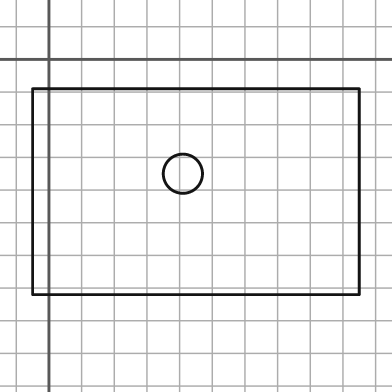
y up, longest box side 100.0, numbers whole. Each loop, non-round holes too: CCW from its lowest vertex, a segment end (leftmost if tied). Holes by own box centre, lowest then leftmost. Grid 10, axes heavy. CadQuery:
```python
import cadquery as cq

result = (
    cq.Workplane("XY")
    .moveTo(-5.0, -72.0)
    .lineTo(95.0, -72.0)
    .lineTo(95.0, -9.0)
    .lineTo(-5.0, -9.0)
    .close()
    .moveTo(41.0, -35.0)
    .circle(6.0)
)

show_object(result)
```